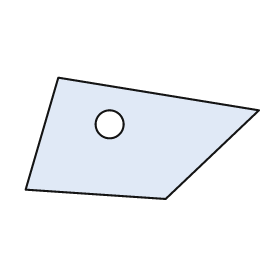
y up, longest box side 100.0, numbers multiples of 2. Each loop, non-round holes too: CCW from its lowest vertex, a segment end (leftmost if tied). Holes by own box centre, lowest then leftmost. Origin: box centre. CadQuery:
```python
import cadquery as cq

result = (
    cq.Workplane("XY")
    .moveTo(10.0, -26.0)
    .lineTo(50.0, 12.0)
    .lineTo(-36.0, 26.0)
    .lineTo(-50.0, -22.0)
    .close()
    .moveTo(-14.0, 6.0)
    .circle(6.0)
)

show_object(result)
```